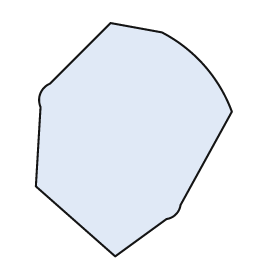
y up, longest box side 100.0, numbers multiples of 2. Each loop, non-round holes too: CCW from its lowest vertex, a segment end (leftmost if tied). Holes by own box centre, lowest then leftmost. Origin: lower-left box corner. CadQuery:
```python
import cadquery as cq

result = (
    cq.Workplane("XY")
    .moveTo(34.0, 0.0)
    .lineTo(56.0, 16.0)
    .threePointArc((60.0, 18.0), (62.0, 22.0))
    .lineTo(84.0, 62.0)
    .threePointArc((72.0, 82.0), (54.0, 96.0))
    .lineTo(32.0, 100.0)
    .lineTo(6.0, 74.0)
    .threePointArc((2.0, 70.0), (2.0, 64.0))
    .lineTo(0.0, 30.0)
    .close()
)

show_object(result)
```